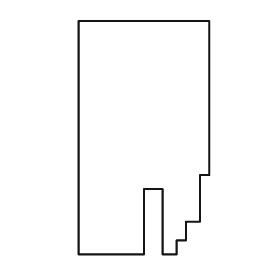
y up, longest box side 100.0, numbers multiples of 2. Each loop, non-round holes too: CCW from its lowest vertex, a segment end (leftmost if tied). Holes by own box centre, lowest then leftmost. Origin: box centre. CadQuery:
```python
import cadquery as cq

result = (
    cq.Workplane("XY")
    .moveTo(-28.0, -50.0)
    .lineTo(0.0, -50.0)
    .lineTo(0.0, -22.0)
    .lineTo(8.0, -22.0)
    .lineTo(8.0, -50.0)
    .lineTo(14.0, -50.0)
    .lineTo(14.0, -44.0)
    .lineTo(18.0, -44.0)
    .lineTo(18.0, -36.0)
    .lineTo(24.0, -36.0)
    .lineTo(24.0, -16.0)
    .lineTo(28.0, -16.0)
    .lineTo(28.0, 50.0)
    .lineTo(-28.0, 50.0)
    .close()
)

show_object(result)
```